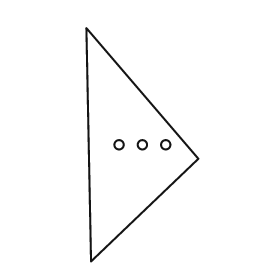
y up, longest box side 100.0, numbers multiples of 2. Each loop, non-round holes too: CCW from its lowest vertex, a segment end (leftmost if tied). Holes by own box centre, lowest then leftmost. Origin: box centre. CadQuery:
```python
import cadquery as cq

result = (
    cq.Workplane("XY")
    .moveTo(-22.0, -50.0)
    .lineTo(24.0, -6.0)
    .lineTo(-24.0, 50.0)
    .close()
    .moveTo(-10.0, 0.0)
    .circle(2.0)
    .moveTo(0.0, 0.0)
    .circle(2.0)
    .moveTo(10.0, 0.0)
    .circle(2.0)
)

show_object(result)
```